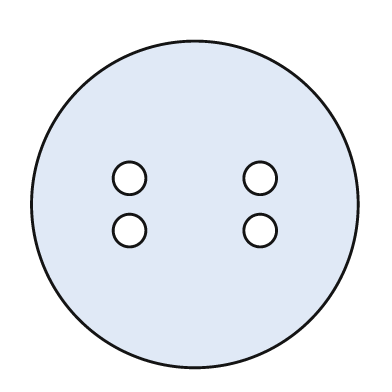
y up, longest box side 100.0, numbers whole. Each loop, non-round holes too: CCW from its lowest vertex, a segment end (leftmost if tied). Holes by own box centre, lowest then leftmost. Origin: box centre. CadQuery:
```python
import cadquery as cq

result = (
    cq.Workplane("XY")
    .moveTo(0.0, 0.0)
    .circle(50.0)
    .moveTo(-20.0, -8.0)
    .circle(5.0)
    .moveTo(20.0, -8.0)
    .circle(5.0)
    .moveTo(-20.0, 8.0)
    .circle(5.0)
    .moveTo(20.0, 8.0)
    .circle(5.0)
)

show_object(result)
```